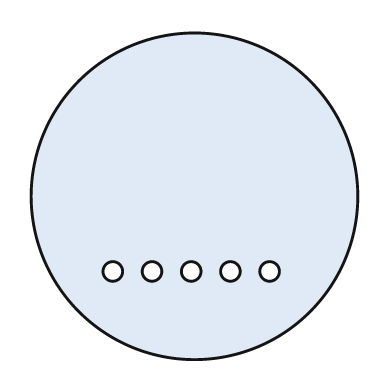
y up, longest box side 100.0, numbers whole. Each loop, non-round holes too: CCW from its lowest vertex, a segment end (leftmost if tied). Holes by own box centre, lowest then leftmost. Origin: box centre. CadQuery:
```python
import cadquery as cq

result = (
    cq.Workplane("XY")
    .moveTo(0.0, 0.0)
    .circle(50.0)
    .moveTo(-25.0, -23.0)
    .circle(3.0)
    .moveTo(-13.0, -23.0)
    .circle(3.0)
    .moveTo(-1.0, -23.0)
    .circle(3.0)
    .moveTo(11.0, -23.0)
    .circle(3.0)
    .moveTo(23.0, -23.0)
    .circle(3.0)
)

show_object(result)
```